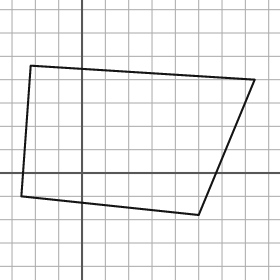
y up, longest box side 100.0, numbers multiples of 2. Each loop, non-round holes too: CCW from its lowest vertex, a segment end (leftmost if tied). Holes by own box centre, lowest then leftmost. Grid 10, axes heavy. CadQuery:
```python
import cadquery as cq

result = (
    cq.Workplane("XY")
    .moveTo(50.0, -18.0)
    .lineTo(74.0, 40.0)
    .lineTo(-22.0, 46.0)
    .lineTo(-26.0, -10.0)
    .close()
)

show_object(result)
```